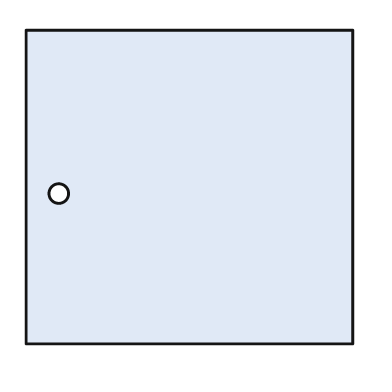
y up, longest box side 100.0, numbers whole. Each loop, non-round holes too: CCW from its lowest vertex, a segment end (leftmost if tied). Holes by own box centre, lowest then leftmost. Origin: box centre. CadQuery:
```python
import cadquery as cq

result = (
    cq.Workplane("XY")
    .moveTo(-50.0, -48.0)
    .lineTo(50.0, -48.0)
    .lineTo(50.0, 48.0)
    .lineTo(-50.0, 48.0)
    .close()
    .moveTo(-40.0, -2.0)
    .circle(3.0)
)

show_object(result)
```